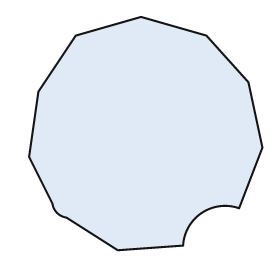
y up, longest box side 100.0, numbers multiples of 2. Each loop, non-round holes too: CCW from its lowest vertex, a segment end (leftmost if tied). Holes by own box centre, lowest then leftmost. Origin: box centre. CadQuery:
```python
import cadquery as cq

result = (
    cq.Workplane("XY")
    .moveTo(-12.0, -50.0)
    .lineTo(16.0, -48.0)
    .threePointArc((24.0, -34.0), (40.0, -32.0))
    .lineTo(50.0, -6.0)
    .lineTo(44.0, 22.0)
    .lineTo(26.0, 42.0)
    .lineTo(-2.0, 50.0)
    .lineTo(-30.0, 42.0)
    .lineTo(-46.0, 18.0)
    .lineTo(-50.0, -10.0)
    .lineTo(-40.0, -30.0)
    .threePointArc((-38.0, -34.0), (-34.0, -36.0))
    .close()
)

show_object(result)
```